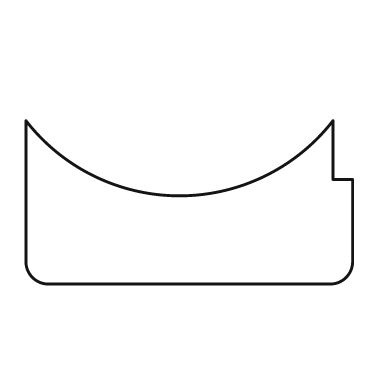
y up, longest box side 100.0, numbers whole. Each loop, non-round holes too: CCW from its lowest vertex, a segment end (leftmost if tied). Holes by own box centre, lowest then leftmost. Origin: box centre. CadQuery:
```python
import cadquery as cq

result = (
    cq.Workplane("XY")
    .moveTo(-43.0, -25.0)
    .lineTo(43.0, -25.0)
    .threePointArc((48.0, -23.0), (50.0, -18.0))
    .lineTo(50.0, 7.0)
    .lineTo(44.0, 7.0)
    .lineTo(44.0, 25.0)
    .threePointArc((-3.0, 2.0), (-50.0, 25.0))
    .lineTo(-50.0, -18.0)
    .threePointArc((-48.0, -23.0), (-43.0, -25.0))
    .close()
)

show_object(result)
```